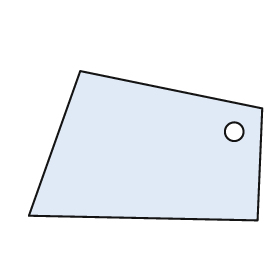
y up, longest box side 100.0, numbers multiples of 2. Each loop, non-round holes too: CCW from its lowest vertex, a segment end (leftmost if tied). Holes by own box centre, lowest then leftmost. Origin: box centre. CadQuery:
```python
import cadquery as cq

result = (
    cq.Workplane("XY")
    .moveTo(48.0, -32.0)
    .lineTo(50.0, 16.0)
    .lineTo(-28.0, 32.0)
    .lineTo(-50.0, -30.0)
    .close()
    .moveTo(38.0, 6.0)
    .circle(4.0)
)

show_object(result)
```